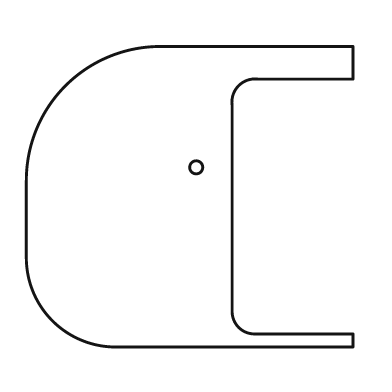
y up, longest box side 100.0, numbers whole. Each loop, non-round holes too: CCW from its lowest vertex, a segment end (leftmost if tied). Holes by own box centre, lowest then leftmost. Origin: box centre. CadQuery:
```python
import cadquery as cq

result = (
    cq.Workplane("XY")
    .moveTo(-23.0, -46.0)
    .lineTo(50.0, -46.0)
    .lineTo(50.0, -42.0)
    .lineTo(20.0, -42.0)
    .threePointArc((15.0, -40.0), (13.0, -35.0))
    .lineTo(13.0, 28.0)
    .threePointArc((15.0, 34.0), (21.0, 36.0))
    .lineTo(50.0, 36.0)
    .lineTo(50.0, 46.0)
    .lineTo(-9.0, 46.0)
    .threePointArc((-38.0, 34.0), (-50.0, 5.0))
    .lineTo(-50.0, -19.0)
    .threePointArc((-42.0, -38.0), (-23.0, -46.0))
    .close()
    .moveTo(2.0, 9.0)
    .circle(2.0)
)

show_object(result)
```